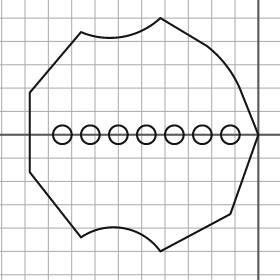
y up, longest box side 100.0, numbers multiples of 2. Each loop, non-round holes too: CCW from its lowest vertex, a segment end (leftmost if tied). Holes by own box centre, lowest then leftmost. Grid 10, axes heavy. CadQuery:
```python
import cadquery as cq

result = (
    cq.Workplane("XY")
    .moveTo(-42.0, -50.0)
    .lineTo(-12.0, -34.0)
    .lineTo(0.0, 0.0)
    .lineTo(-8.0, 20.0)
    .threePointArc((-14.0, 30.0), (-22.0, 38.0))
    .lineTo(-42.0, 50.0)
    .threePointArc((-58.0, 42.0), (-76.0, 44.0))
    .lineTo(-98.0, 18.0)
    .lineTo(-98.0, -16.0)
    .lineTo(-76.0, -44.0)
    .threePointArc((-58.0, -40.0), (-42.0, -50.0))
    .close()
    .moveTo(-84.0, 0.0)
    .circle(4.0)
    .moveTo(-72.0, 0.0)
    .circle(4.0)
    .moveTo(-60.0, 0.0)
    .circle(4.0)
    .moveTo(-48.0, 0.0)
    .circle(4.0)
    .moveTo(-36.0, 0.0)
    .circle(4.0)
    .moveTo(-24.0, 0.0)
    .circle(4.0)
    .moveTo(-12.0, 0.0)
    .circle(4.0)
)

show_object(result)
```